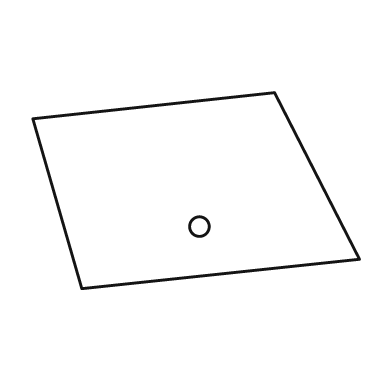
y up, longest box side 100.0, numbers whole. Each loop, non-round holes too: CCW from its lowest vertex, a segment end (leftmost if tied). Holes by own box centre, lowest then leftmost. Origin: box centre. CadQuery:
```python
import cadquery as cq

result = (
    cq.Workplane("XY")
    .moveTo(-35.0, -30.0)
    .lineTo(50.0, -21.0)
    .lineTo(24.0, 30.0)
    .lineTo(-50.0, 22.0)
    .close()
    .moveTo(1.0, -11.0)
    .circle(3.0)
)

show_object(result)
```